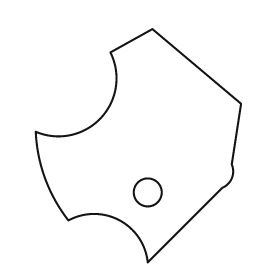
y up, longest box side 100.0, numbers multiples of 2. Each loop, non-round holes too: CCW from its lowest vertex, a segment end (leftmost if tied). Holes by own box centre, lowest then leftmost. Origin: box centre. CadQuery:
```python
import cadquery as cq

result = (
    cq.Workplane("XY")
    .moveTo(4.0, -50.0)
    .lineTo(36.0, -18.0)
    .threePointArc((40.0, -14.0), (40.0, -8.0))
    .lineTo(44.0, 18.0)
    .lineTo(6.0, 50.0)
    .lineTo(-12.0, 40.0)
    .threePointArc((-16.0, 12.0), (-44.0, 6.0))
    .threePointArc((-40.0, -14.0), (-30.0, -32.0))
    .threePointArc((-8.0, -32.0), (4.0, -50.0))
    .close()
    .moveTo(4.0, -20.0)
    .circle(6.0)
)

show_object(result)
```